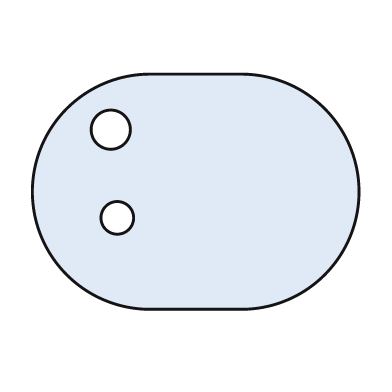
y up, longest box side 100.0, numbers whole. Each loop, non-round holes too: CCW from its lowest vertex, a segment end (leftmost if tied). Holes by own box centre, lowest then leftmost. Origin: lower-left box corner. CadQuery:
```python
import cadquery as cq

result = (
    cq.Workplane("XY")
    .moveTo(36.0, 0.0)
    .lineTo(64.0, 0.0)
    .threePointArc((100.0, 36.0), (64.0, 72.0))
    .lineTo(36.0, 72.0)
    .threePointArc((0.0, 36.0), (36.0, 0.0))
    .close()
    .moveTo(26.0, 28.0)
    .circle(5.0)
    .moveTo(24.0, 55.0)
    .circle(6.0)
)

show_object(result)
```